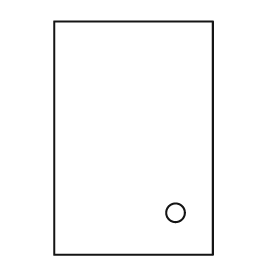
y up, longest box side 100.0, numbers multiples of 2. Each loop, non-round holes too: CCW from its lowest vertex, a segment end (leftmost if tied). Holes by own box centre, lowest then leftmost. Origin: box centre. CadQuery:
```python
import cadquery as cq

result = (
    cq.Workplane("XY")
    .moveTo(-34.0, -50.0)
    .lineTo(34.0, -50.0)
    .lineTo(34.0, 50.0)
    .lineTo(-34.0, 50.0)
    .close()
    .moveTo(18.0, -32.0)
    .circle(4.0)
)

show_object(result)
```